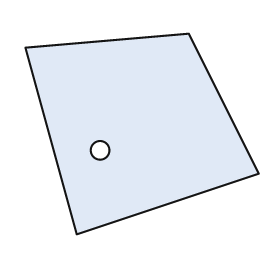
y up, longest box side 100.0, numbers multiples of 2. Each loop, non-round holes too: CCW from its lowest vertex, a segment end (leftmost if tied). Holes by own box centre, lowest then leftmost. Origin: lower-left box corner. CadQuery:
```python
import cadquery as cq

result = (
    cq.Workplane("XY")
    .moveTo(22.0, 0.0)
    .lineTo(100.0, 26.0)
    .lineTo(70.0, 86.0)
    .lineTo(0.0, 80.0)
    .close()
    .moveTo(32.0, 36.0)
    .circle(4.0)
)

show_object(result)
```